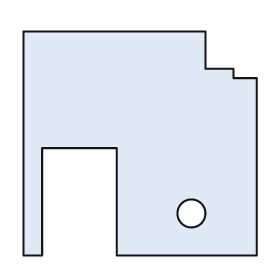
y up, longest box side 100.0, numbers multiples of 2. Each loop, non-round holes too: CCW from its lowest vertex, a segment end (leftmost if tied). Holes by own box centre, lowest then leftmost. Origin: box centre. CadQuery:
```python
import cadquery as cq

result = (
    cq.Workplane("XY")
    .moveTo(-50.0, -48.0)
    .lineTo(-42.0, -48.0)
    .lineTo(-42.0, -2.0)
    .lineTo(-10.0, -2.0)
    .lineTo(-10.0, -48.0)
    .lineTo(50.0, -48.0)
    .lineTo(50.0, 28.0)
    .lineTo(40.0, 28.0)
    .lineTo(40.0, 32.0)
    .lineTo(28.0, 32.0)
    .lineTo(28.0, 48.0)
    .lineTo(-50.0, 48.0)
    .close()
    .moveTo(22.0, -30.0)
    .circle(6.0)
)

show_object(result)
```